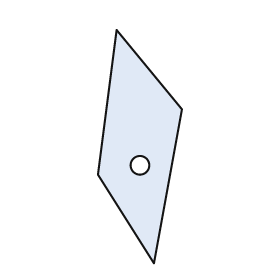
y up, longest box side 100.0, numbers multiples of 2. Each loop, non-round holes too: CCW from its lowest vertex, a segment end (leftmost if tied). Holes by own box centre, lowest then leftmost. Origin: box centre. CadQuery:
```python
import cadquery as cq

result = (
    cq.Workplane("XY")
    .moveTo(6.0, -50.0)
    .lineTo(18.0, 16.0)
    .lineTo(-10.0, 50.0)
    .lineTo(-18.0, -12.0)
    .close()
    .moveTo(0.0, -8.0)
    .circle(4.0)
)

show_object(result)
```